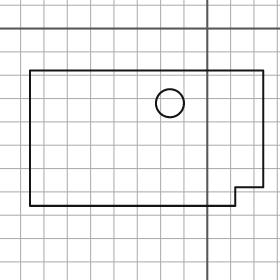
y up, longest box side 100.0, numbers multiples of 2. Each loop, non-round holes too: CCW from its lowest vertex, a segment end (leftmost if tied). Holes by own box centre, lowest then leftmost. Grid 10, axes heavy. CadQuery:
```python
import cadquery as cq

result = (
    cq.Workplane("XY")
    .moveTo(-76.0, -76.0)
    .lineTo(12.0, -76.0)
    .lineTo(12.0, -68.0)
    .lineTo(24.0, -68.0)
    .lineTo(24.0, -18.0)
    .lineTo(-76.0, -18.0)
    .close()
    .moveTo(-16.0, -32.0)
    .circle(6.0)
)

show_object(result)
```